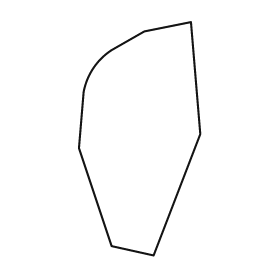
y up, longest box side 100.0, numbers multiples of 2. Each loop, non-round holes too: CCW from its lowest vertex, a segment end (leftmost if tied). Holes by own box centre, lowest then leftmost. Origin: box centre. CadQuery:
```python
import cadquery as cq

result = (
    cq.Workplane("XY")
    .moveTo(6.0, -50.0)
    .lineTo(26.0, 2.0)
    .lineTo(22.0, 50.0)
    .lineTo(2.0, 46.0)
    .lineTo(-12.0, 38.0)
    .threePointArc((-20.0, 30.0), (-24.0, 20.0))
    .lineTo(-26.0, -4.0)
    .lineTo(-12.0, -46.0)
    .close()
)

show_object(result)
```